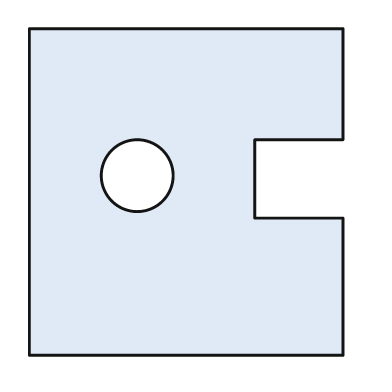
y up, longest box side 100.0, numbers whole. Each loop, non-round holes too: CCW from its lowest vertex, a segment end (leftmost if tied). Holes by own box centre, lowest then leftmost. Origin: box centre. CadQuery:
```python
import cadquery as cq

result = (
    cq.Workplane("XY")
    .moveTo(-48.0, -50.0)
    .lineTo(48.0, -50.0)
    .lineTo(48.0, -8.0)
    .lineTo(21.0, -8.0)
    .lineTo(21.0, 16.0)
    .lineTo(48.0, 16.0)
    .lineTo(48.0, 50.0)
    .lineTo(-48.0, 50.0)
    .close()
    .moveTo(-15.0, 5.0)
    .circle(11.0)
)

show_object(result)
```